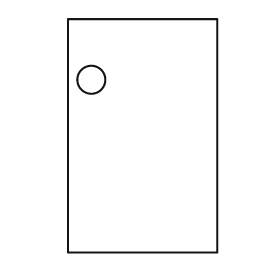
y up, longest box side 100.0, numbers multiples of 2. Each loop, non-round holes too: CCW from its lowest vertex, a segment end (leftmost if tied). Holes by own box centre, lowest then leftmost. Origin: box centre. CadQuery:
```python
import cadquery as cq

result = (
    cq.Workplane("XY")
    .moveTo(-32.0, -50.0)
    .lineTo(32.0, -50.0)
    .lineTo(32.0, 50.0)
    .lineTo(-32.0, 50.0)
    .close()
    .moveTo(-22.0, 24.0)
    .circle(6.0)
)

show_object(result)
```